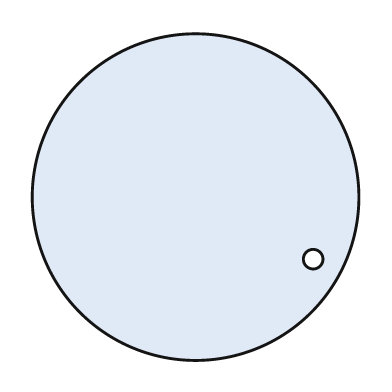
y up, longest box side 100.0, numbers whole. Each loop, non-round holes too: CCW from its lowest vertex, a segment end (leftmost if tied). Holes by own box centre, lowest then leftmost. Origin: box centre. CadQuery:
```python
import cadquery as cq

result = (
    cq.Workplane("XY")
    .moveTo(0.0, 0.0)
    .circle(50.0)
    .moveTo(36.0, -19.0)
    .circle(3.0)
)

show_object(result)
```